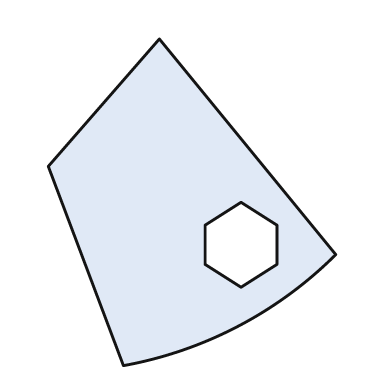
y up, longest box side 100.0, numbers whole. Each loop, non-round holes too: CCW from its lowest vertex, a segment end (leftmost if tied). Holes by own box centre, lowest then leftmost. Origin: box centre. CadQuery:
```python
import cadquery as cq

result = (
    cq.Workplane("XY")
    .moveTo(-21.0, -50.0)
    .threePointArc((14.0, -38.0), (44.0, -16.0))
    .lineTo(-10.0, 50.0)
    .lineTo(-44.0, 11.0)
    .close()
    .moveTo(15.0, -26.0)
    .lineTo(26.0, -19.0)
    .lineTo(26.0, -7.0)
    .lineTo(15.0, 0.0)
    .lineTo(4.0, -7.0)
    .lineTo(4.0, -19.0)
    .close()
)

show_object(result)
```